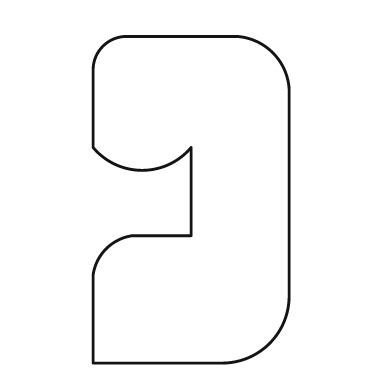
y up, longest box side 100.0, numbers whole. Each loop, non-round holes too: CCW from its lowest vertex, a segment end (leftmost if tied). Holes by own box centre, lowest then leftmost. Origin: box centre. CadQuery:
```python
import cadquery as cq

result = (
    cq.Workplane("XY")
    .moveTo(-30.0, -50.0)
    .lineTo(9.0, -50.0)
    .threePointArc((24.0, -44.0), (30.0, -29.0))
    .lineTo(30.0, 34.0)
    .threePointArc((25.0, 45.0), (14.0, 50.0))
    .lineTo(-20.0, 50.0)
    .threePointArc((-27.0, 47.0), (-30.0, 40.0))
    .lineTo(-30.0, 16.0)
    .threePointArc((-15.0, 9.0), (0.0, 16.0))
    .lineTo(0.0, -11.0)
    .lineTo(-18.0, -11.0)
    .threePointArc((-26.0, -15.0), (-30.0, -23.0))
    .close()
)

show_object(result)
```